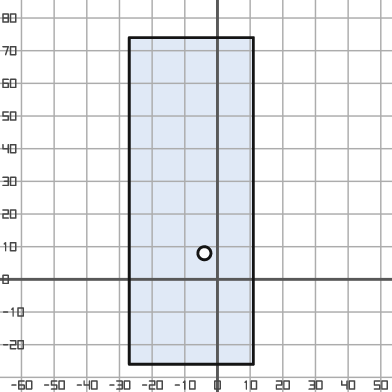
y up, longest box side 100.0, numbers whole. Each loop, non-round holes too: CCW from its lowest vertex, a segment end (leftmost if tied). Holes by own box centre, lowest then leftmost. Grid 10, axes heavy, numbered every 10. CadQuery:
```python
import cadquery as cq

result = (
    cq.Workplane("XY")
    .moveTo(-27.0, -26.0)
    .lineTo(11.0, -26.0)
    .lineTo(11.0, 74.0)
    .lineTo(-27.0, 74.0)
    .close()
    .moveTo(-4.0, 8.0)
    .circle(2.0)
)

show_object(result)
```